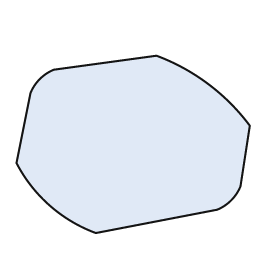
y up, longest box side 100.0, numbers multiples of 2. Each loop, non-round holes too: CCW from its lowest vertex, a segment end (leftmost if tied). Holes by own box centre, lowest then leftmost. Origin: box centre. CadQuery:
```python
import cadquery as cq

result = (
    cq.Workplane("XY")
    .moveTo(-16.0, -38.0)
    .lineTo(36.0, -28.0)
    .threePointArc((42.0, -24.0), (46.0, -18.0))
    .lineTo(50.0, 8.0)
    .threePointArc((32.0, 26.0), (10.0, 38.0))
    .lineTo(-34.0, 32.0)
    .threePointArc((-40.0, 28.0), (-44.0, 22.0))
    .lineTo(-50.0, -8.0)
    .threePointArc((-36.0, -26.0), (-16.0, -38.0))
    .close()
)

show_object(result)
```